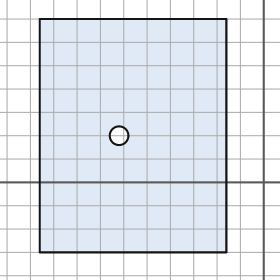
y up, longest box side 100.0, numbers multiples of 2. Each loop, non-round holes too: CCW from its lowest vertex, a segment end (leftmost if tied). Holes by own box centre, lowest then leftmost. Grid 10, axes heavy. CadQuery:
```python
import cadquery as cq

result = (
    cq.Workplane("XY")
    .moveTo(-96.0, -30.0)
    .lineTo(-16.0, -30.0)
    .lineTo(-16.0, 70.0)
    .lineTo(-96.0, 70.0)
    .close()
    .moveTo(-62.0, 20.0)
    .circle(4.0)
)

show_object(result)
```